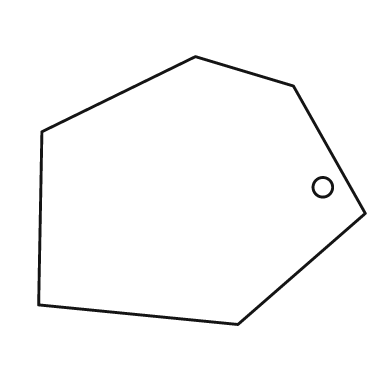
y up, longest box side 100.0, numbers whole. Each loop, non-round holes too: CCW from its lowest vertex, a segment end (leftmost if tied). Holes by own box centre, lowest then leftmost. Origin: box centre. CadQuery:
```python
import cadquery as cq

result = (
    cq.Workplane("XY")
    .moveTo(11.0, -41.0)
    .lineTo(50.0, -7.0)
    .lineTo(28.0, 32.0)
    .lineTo(-2.0, 41.0)
    .lineTo(-49.0, 18.0)
    .lineTo(-50.0, -35.0)
    .close()
    .moveTo(37.0, 1.0)
    .circle(3.0)
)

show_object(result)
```